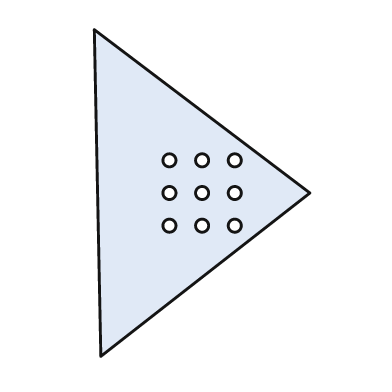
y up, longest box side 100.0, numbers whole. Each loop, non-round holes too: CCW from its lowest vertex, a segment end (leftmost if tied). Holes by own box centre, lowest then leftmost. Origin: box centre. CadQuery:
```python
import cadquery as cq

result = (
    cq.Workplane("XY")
    .moveTo(-31.0, -50.0)
    .lineTo(33.0, 0.0)
    .lineTo(-33.0, 50.0)
    .close()
    .moveTo(-10.0, -10.0)
    .circle(2.0)
    .moveTo(0.0, -10.0)
    .circle(2.0)
    .moveTo(10.0, -10.0)
    .circle(2.0)
    .moveTo(-10.0, 0.0)
    .circle(2.0)
    .moveTo(0.0, 0.0)
    .circle(2.0)
    .moveTo(10.0, 0.0)
    .circle(2.0)
    .moveTo(-10.0, 10.0)
    .circle(2.0)
    .moveTo(0.0, 10.0)
    .circle(2.0)
    .moveTo(10.0, 10.0)
    .circle(2.0)
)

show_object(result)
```